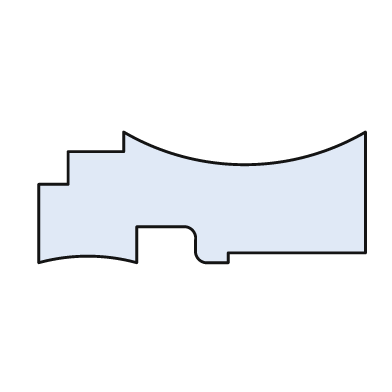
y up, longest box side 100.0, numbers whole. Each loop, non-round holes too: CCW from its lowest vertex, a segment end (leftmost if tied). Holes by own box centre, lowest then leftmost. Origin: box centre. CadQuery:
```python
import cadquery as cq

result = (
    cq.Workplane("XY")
    .moveTo(-50.0, -20.0)
    .threePointArc((-35.0, -18.0), (-20.0, -20.0))
    .lineTo(-20.0, -9.0)
    .lineTo(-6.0, -9.0)
    .threePointArc((-3.0, -10.0), (-2.0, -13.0))
    .lineTo(-2.0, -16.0)
    .threePointArc((-1.0, -19.0), (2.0, -20.0))
    .lineTo(8.0, -20.0)
    .lineTo(8.0, -17.0)
    .lineTo(50.0, -17.0)
    .lineTo(50.0, 20.0)
    .threePointArc((13.0, 10.0), (-24.0, 20.0))
    .lineTo(-24.0, 14.0)
    .lineTo(-41.0, 14.0)
    .lineTo(-41.0, 4.0)
    .lineTo(-50.0, 4.0)
    .close()
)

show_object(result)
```